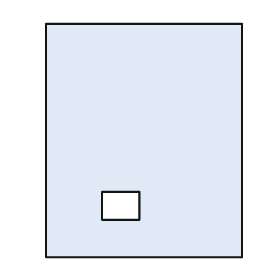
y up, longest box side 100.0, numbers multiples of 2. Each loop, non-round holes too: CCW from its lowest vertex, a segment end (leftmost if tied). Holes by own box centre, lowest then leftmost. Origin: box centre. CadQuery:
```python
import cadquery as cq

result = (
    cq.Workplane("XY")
    .moveTo(-42.0, -50.0)
    .lineTo(42.0, -50.0)
    .lineTo(42.0, 50.0)
    .lineTo(-42.0, 50.0)
    .close()
    .moveTo(-18.0, -34.0)
    .lineTo(-2.0, -34.0)
    .lineTo(-2.0, -22.0)
    .lineTo(-18.0, -22.0)
    .close()
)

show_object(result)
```